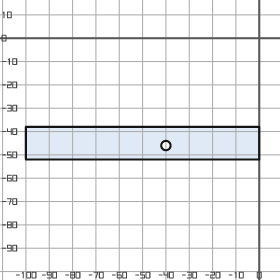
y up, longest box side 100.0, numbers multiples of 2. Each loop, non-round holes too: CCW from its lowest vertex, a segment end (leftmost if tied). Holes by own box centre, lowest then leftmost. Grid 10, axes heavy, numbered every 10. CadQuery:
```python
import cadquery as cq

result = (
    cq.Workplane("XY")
    .moveTo(-100.0, -52.0)
    .lineTo(0.0, -52.0)
    .lineTo(0.0, -38.0)
    .lineTo(-100.0, -38.0)
    .close()
    .moveTo(-40.0, -46.0)
    .circle(2.0)
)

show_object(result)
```